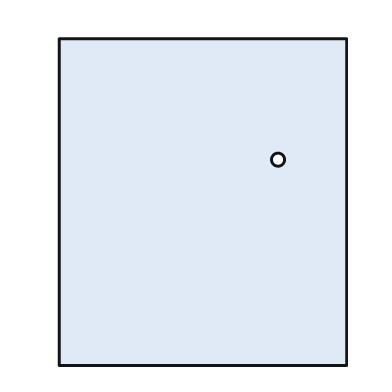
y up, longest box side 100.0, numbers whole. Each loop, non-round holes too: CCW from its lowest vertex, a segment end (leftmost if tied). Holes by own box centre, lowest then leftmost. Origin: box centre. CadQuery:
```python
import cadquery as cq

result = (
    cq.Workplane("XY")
    .moveTo(-44.0, -50.0)
    .lineTo(44.0, -50.0)
    .lineTo(44.0, 50.0)
    .lineTo(-44.0, 50.0)
    .close()
    .moveTo(23.0, 13.0)
    .circle(2.0)
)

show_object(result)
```